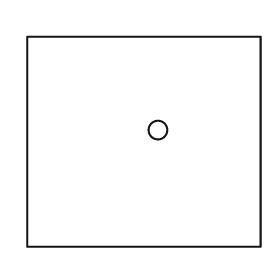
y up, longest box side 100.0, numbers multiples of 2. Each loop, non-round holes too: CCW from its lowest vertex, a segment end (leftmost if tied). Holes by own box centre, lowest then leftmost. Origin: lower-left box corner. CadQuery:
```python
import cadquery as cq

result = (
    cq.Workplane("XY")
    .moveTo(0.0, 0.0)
    .lineTo(100.0, 0.0)
    .lineTo(100.0, 90.0)
    .lineTo(0.0, 90.0)
    .close()
    .moveTo(56.0, 50.0)
    .circle(4.0)
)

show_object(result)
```